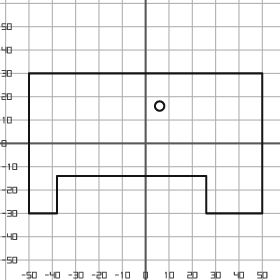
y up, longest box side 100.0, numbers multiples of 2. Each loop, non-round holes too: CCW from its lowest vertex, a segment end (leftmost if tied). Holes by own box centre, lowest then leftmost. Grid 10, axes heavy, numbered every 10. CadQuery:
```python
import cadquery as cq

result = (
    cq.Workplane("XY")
    .moveTo(-50.0, -30.0)
    .lineTo(-38.0, -30.0)
    .lineTo(-38.0, -14.0)
    .lineTo(26.0, -14.0)
    .lineTo(26.0, -30.0)
    .lineTo(50.0, -30.0)
    .lineTo(50.0, 30.0)
    .lineTo(-50.0, 30.0)
    .close()
    .moveTo(6.0, 16.0)
    .circle(2.0)
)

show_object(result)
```